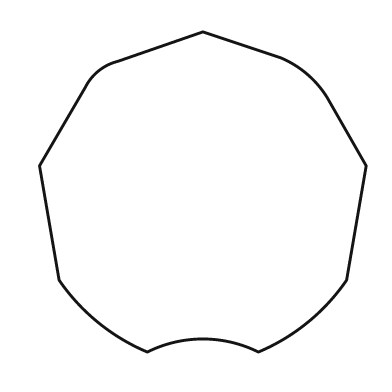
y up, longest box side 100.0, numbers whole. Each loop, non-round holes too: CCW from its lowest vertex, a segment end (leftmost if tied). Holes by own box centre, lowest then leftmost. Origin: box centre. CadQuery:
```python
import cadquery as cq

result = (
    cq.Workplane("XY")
    .moveTo(-17.0, -49.0)
    .threePointArc((0.0, -45.0), (17.0, -49.0))
    .threePointArc((32.0, -40.0), (44.0, -27.0))
    .lineTo(50.0, 8.0)
    .lineTo(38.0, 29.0)
    .threePointArc((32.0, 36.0), (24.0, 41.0))
    .lineTo(0.0, 49.0)
    .lineTo(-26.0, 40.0)
    .threePointArc((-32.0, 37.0), (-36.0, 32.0))
    .lineTo(-50.0, 8.0)
    .lineTo(-44.0, -27.0)
    .threePointArc((-32.0, -40.0), (-17.0, -49.0))
    .close()
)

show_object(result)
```